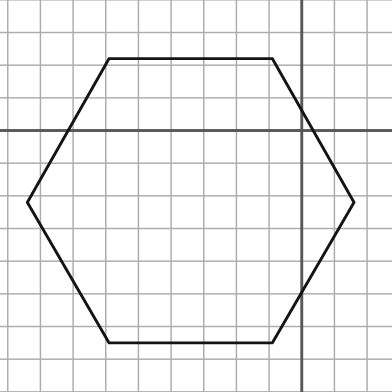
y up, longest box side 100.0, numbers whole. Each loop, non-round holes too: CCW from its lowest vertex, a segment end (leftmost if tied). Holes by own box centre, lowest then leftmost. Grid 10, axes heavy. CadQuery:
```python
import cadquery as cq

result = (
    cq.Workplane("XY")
    .moveTo(-59.0, -65.0)
    .lineTo(-9.0, -65.0)
    .lineTo(16.0, -22.0)
    .lineTo(-9.0, 22.0)
    .lineTo(-59.0, 22.0)
    .lineTo(-84.0, -22.0)
    .close()
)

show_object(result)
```